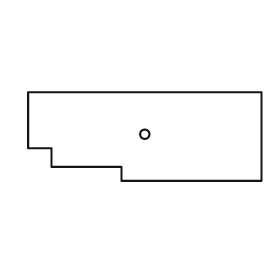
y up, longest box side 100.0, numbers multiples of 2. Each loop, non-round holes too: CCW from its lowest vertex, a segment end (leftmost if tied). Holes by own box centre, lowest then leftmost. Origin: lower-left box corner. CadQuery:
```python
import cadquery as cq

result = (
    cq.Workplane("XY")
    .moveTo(40.0, 0.0)
    .lineTo(100.0, 0.0)
    .lineTo(100.0, 38.0)
    .lineTo(0.0, 38.0)
    .lineTo(0.0, 14.0)
    .lineTo(10.0, 14.0)
    .lineTo(10.0, 6.0)
    .lineTo(40.0, 6.0)
    .close()
    .moveTo(50.0, 20.0)
    .circle(2.0)
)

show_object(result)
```